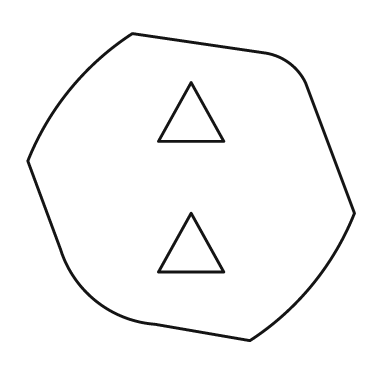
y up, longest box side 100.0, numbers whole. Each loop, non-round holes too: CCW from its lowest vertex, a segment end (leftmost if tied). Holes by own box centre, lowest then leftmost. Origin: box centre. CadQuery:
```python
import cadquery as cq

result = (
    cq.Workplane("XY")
    .moveTo(18.0, -47.0)
    .threePointArc((37.0, -30.0), (50.0, -8.0))
    .lineTo(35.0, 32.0)
    .threePointArc((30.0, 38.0), (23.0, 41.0))
    .lineTo(-18.0, 47.0)
    .threePointArc((-37.0, 30.0), (-50.0, 8.0))
    .lineTo(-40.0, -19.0)
    .threePointArc((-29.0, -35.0), (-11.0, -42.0))
    .close()
    .moveTo(-10.0, -26.0)
    .lineTo(10.0, -26.0)
    .lineTo(0.0, -8.0)
    .close()
    .moveTo(-10.0, 14.0)
    .lineTo(10.0, 14.0)
    .lineTo(0.0, 32.0)
    .close()
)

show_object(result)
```